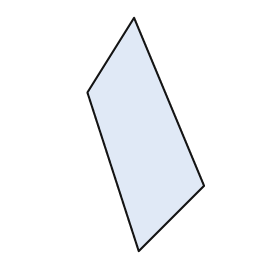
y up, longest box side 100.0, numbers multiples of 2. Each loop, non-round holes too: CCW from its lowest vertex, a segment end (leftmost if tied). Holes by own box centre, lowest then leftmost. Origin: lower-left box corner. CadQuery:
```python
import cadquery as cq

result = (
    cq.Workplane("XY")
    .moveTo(22.0, 0.0)
    .lineTo(50.0, 28.0)
    .lineTo(20.0, 100.0)
    .lineTo(0.0, 68.0)
    .close()
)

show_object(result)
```